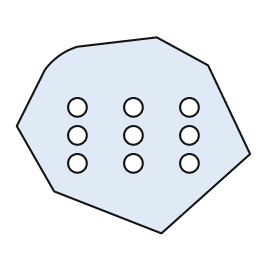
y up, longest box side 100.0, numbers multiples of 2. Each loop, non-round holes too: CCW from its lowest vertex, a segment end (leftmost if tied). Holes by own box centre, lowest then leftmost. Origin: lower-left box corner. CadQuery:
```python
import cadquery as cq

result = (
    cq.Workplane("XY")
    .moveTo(62.0, 0.0)
    .lineTo(100.0, 34.0)
    .lineTo(82.0, 72.0)
    .lineTo(60.0, 84.0)
    .lineTo(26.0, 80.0)
    .threePointArc((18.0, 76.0), (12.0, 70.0))
    .lineTo(0.0, 46.0)
    .lineTo(16.0, 18.0)
    .close()
    .moveTo(26.0, 30.0)
    .circle(4.0)
    .moveTo(50.0, 30.0)
    .circle(4.0)
    .moveTo(74.0, 30.0)
    .circle(4.0)
    .moveTo(26.0, 42.0)
    .circle(4.0)
    .moveTo(50.0, 42.0)
    .circle(4.0)
    .moveTo(74.0, 42.0)
    .circle(4.0)
    .moveTo(26.0, 54.0)
    .circle(4.0)
    .moveTo(50.0, 54.0)
    .circle(4.0)
    .moveTo(74.0, 54.0)
    .circle(4.0)
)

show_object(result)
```